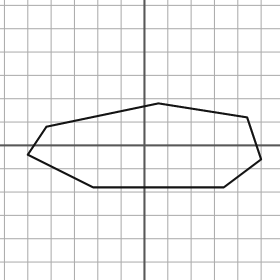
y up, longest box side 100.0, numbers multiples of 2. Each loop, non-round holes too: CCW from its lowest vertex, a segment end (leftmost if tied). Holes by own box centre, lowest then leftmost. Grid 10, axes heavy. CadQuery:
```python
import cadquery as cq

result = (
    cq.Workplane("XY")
    .moveTo(-22.0, -18.0)
    .lineTo(34.0, -18.0)
    .lineTo(50.0, -6.0)
    .lineTo(44.0, 12.0)
    .lineTo(6.0, 18.0)
    .lineTo(-42.0, 8.0)
    .lineTo(-50.0, -4.0)
    .close()
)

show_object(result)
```